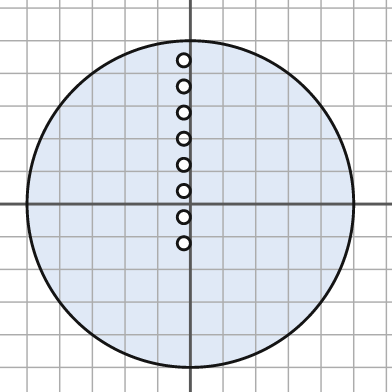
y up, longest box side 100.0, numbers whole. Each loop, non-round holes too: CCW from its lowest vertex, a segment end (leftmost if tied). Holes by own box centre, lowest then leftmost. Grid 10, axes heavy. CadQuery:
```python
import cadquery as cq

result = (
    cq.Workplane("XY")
    .moveTo(0.0, 0.0)
    .circle(50.0)
    .moveTo(-2.0, -12.0)
    .circle(2.0)
    .moveTo(-2.0, -4.0)
    .circle(2.0)
    .moveTo(-2.0, 4.0)
    .circle(2.0)
    .moveTo(-2.0, 12.0)
    .circle(2.0)
    .moveTo(-2.0, 20.0)
    .circle(2.0)
    .moveTo(-2.0, 28.0)
    .circle(2.0)
    .moveTo(-2.0, 36.0)
    .circle(2.0)
    .moveTo(-2.0, 44.0)
    .circle(2.0)
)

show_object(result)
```